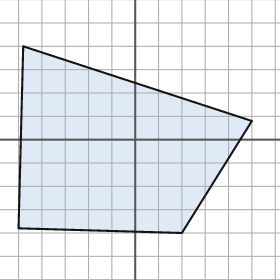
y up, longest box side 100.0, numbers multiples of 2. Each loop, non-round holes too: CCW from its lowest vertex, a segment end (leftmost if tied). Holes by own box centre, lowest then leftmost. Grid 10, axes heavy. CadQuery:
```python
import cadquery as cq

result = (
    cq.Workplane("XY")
    .moveTo(20.0, -40.0)
    .lineTo(50.0, 8.0)
    .lineTo(-48.0, 40.0)
    .lineTo(-50.0, -38.0)
    .close()
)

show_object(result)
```